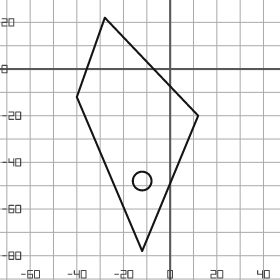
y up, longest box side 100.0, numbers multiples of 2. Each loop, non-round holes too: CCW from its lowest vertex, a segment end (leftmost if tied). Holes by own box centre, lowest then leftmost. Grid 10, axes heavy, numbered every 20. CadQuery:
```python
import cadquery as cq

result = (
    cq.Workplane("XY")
    .moveTo(-12.0, -78.0)
    .lineTo(12.0, -20.0)
    .lineTo(-28.0, 22.0)
    .lineTo(-40.0, -12.0)
    .close()
    .moveTo(-12.0, -48.0)
    .circle(4.0)
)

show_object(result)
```